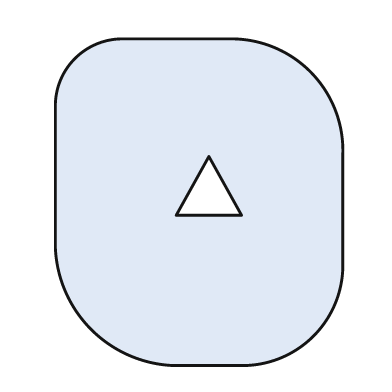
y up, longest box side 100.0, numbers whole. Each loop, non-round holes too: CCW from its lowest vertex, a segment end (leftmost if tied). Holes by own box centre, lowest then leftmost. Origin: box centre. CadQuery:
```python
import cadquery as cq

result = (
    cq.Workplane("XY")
    .moveTo(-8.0, -50.0)
    .lineTo(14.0, -50.0)
    .threePointArc((35.0, -41.0), (44.0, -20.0))
    .lineTo(44.0, 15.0)
    .threePointArc((34.0, 40.0), (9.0, 50.0))
    .lineTo(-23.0, 50.0)
    .threePointArc((-38.0, 44.0), (-44.0, 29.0))
    .lineTo(-44.0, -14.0)
    .threePointArc((-33.0, -39.0), (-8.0, -50.0))
    .close()
    .moveTo(-7.0, -4.0)
    .lineTo(13.0, -4.0)
    .lineTo(3.0, 14.0)
    .close()
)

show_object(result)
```